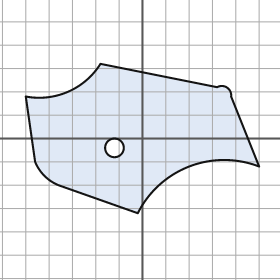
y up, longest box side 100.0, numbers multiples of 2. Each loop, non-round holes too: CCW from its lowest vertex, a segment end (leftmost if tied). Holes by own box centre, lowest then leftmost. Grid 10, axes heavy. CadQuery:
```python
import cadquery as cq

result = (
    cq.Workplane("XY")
    .moveTo(-2.0, -32.0)
    .threePointArc((20.0, -12.0), (50.0, -12.0))
    .lineTo(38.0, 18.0)
    .threePointArc((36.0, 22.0), (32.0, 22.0))
    .lineTo(-18.0, 32.0)
    .threePointArc((-32.0, 20.0), (-50.0, 18.0))
    .lineTo(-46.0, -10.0)
    .threePointArc((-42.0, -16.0), (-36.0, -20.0))
    .close()
    .moveTo(-12.0, -4.0)
    .circle(4.0)
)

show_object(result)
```